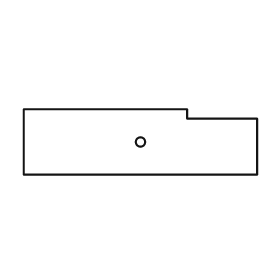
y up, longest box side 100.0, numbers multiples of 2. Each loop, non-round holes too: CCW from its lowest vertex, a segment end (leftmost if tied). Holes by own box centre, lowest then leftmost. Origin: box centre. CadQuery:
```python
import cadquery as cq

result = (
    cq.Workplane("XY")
    .moveTo(-50.0, -14.0)
    .lineTo(50.0, -14.0)
    .lineTo(50.0, 10.0)
    .lineTo(20.0, 10.0)
    .lineTo(20.0, 14.0)
    .lineTo(-50.0, 14.0)
    .close()
    .moveTo(0.0, 0.0)
    .circle(2.0)
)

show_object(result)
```